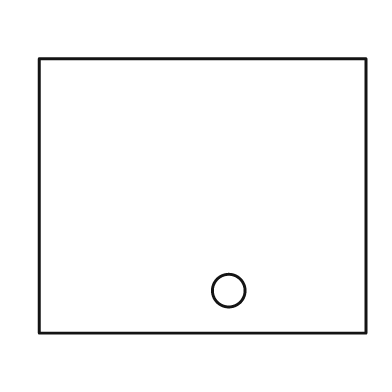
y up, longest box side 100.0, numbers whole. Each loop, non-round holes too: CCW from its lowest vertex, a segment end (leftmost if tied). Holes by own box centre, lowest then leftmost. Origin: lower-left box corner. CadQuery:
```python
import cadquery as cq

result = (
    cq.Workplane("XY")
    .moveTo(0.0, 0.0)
    .lineTo(100.0, 0.0)
    .lineTo(100.0, 84.0)
    .lineTo(0.0, 84.0)
    .close()
    .moveTo(58.0, 13.0)
    .circle(5.0)
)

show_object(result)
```